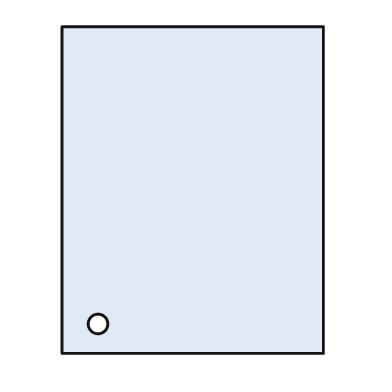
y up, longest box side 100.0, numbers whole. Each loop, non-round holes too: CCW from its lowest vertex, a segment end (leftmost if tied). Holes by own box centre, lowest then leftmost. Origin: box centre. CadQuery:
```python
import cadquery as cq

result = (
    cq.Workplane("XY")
    .moveTo(-40.0, -50.0)
    .lineTo(40.0, -50.0)
    .lineTo(40.0, 50.0)
    .lineTo(-40.0, 50.0)
    .close()
    .moveTo(-29.0, -41.0)
    .circle(3.0)
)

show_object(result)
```